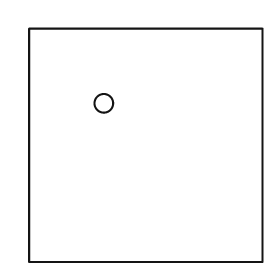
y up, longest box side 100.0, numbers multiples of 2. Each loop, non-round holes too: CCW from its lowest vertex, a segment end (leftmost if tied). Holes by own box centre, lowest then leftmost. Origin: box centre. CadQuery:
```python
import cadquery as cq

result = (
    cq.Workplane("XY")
    .moveTo(-50.0, -50.0)
    .lineTo(50.0, -50.0)
    .lineTo(50.0, 50.0)
    .lineTo(-50.0, 50.0)
    .close()
    .moveTo(-18.0, 18.0)
    .circle(4.0)
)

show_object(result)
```